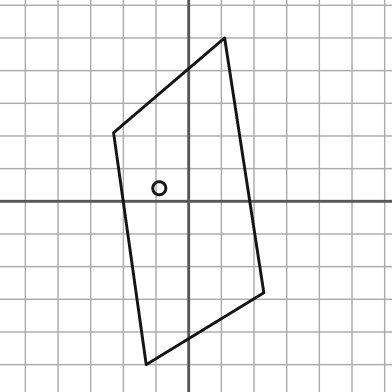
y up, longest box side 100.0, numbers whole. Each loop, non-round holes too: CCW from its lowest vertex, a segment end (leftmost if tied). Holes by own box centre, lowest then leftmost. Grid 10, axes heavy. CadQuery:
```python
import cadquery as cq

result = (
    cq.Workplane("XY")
    .moveTo(-13.0, -50.0)
    .lineTo(23.0, -28.0)
    .lineTo(11.0, 50.0)
    .lineTo(-23.0, 21.0)
    .close()
    .moveTo(-9.0, 4.0)
    .circle(2.0)
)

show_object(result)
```